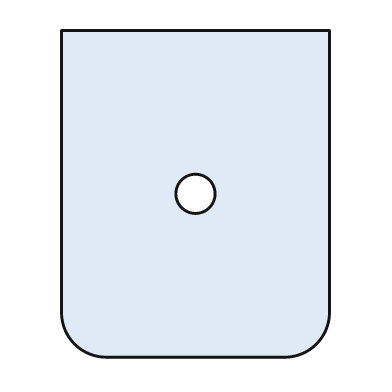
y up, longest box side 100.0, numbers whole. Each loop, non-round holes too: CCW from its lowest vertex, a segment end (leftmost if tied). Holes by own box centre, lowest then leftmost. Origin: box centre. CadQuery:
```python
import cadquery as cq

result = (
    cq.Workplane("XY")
    .moveTo(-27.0, -50.0)
    .lineTo(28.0, -50.0)
    .threePointArc((37.0, -46.0), (41.0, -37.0))
    .lineTo(41.0, 50.0)
    .lineTo(-41.0, 50.0)
    .lineTo(-41.0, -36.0)
    .threePointArc((-37.0, -46.0), (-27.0, -50.0))
    .close()
    .moveTo(0.0, 0.0)
    .circle(6.0)
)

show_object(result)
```